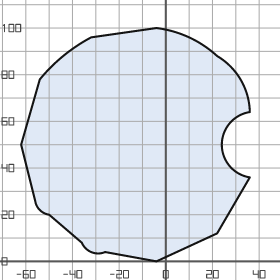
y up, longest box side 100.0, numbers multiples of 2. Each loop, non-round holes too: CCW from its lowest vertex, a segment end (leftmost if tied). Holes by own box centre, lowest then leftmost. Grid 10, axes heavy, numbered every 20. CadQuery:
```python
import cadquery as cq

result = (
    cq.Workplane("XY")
    .moveTo(-4.0, 0.0)
    .lineTo(22.0, 12.0)
    .lineTo(36.0, 36.0)
    .threePointArc((24.0, 50.0), (36.0, 64.0))
    .threePointArc((32.0, 78.0), (22.0, 88.0))
    .threePointArc((10.0, 96.0), (-4.0, 100.0))
    .lineTo(-32.0, 96.0)
    .threePointArc((-44.0, 88.0), (-54.0, 78.0))
    .lineTo(-62.0, 50.0)
    .lineTo(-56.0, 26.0)
    .threePointArc((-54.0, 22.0), (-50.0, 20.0))
    .lineTo(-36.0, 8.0)
    .threePointArc((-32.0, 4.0), (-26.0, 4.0))
    .close()
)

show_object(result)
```